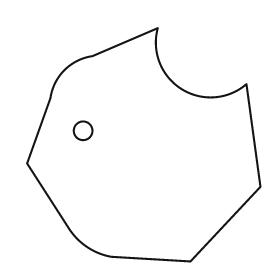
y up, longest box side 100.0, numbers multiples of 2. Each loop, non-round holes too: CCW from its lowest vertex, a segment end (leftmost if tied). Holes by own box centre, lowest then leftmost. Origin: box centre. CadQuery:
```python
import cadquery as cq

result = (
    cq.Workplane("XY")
    .moveTo(20.0, -50.0)
    .lineTo(50.0, -18.0)
    .lineTo(44.0, 26.0)
    .threePointArc((16.0, 24.0), (6.0, 50.0))
    .lineTo(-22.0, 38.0)
    .threePointArc((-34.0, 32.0), (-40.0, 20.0))
    .lineTo(-50.0, -8.0)
    .lineTo(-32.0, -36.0)
    .threePointArc((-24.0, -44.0), (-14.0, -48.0))
    .close()
    .moveTo(-26.0, 6.0)
    .circle(4.0)
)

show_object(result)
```